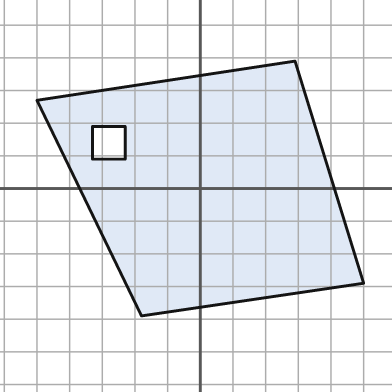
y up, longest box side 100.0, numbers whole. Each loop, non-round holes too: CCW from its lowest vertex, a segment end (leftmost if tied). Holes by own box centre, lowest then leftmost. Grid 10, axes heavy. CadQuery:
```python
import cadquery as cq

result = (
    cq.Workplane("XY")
    .moveTo(-18.0, -39.0)
    .lineTo(50.0, -29.0)
    .lineTo(29.0, 39.0)
    .lineTo(-50.0, 27.0)
    .close()
    .moveTo(-33.0, 9.0)
    .lineTo(-23.0, 9.0)
    .lineTo(-23.0, 19.0)
    .lineTo(-33.0, 19.0)
    .close()
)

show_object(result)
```